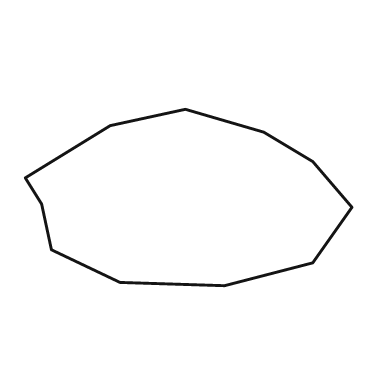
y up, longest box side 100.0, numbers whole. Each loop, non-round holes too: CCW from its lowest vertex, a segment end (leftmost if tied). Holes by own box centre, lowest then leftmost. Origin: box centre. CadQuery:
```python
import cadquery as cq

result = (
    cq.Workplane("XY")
    .moveTo(11.0, -27.0)
    .lineTo(38.0, -20.0)
    .lineTo(50.0, -3.0)
    .lineTo(38.0, 11.0)
    .lineTo(23.0, 20.0)
    .lineTo(-1.0, 27.0)
    .lineTo(-24.0, 22.0)
    .lineTo(-50.0, 6.0)
    .lineTo(-45.0, -2.0)
    .lineTo(-42.0, -16.0)
    .lineTo(-21.0, -26.0)
    .close()
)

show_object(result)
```